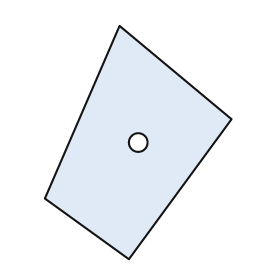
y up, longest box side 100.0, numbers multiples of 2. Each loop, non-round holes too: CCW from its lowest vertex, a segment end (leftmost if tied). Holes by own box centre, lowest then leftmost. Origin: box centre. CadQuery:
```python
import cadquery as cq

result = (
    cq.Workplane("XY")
    .moveTo(-4.0, -50.0)
    .lineTo(40.0, 10.0)
    .lineTo(-8.0, 50.0)
    .lineTo(-40.0, -24.0)
    .close()
    .moveTo(0.0, 0.0)
    .circle(4.0)
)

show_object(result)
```